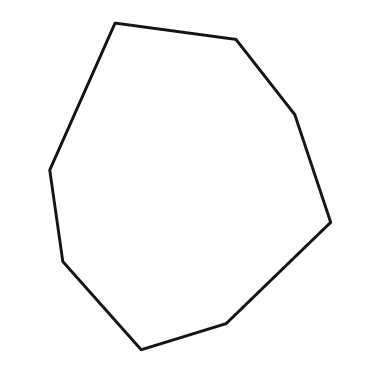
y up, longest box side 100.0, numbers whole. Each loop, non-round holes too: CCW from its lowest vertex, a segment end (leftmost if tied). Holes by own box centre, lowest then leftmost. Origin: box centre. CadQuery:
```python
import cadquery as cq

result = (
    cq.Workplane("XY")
    .moveTo(-15.0, -50.0)
    .lineTo(11.0, -42.0)
    .lineTo(43.0, -11.0)
    .lineTo(32.0, 22.0)
    .lineTo(14.0, 45.0)
    .lineTo(-23.0, 50.0)
    .lineTo(-43.0, 5.0)
    .lineTo(-39.0, -23.0)
    .close()
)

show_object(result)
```